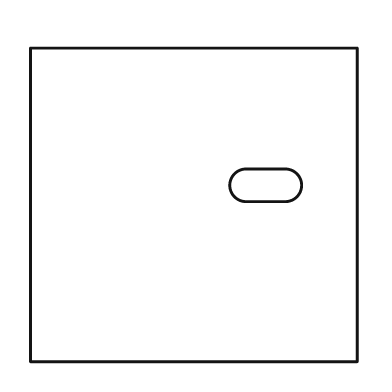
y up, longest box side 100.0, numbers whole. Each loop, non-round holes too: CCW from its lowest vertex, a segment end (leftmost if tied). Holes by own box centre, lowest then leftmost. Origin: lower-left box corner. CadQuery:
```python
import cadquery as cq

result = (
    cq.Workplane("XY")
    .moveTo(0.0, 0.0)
    .lineTo(100.0, 0.0)
    .lineTo(100.0, 96.0)
    .lineTo(0.0, 96.0)
    .close()
    .moveTo(66.0, 49.0)
    .lineTo(78.0, 49.0)
    .threePointArc((83.0, 54.0), (78.0, 59.0))
    .lineTo(66.0, 59.0)
    .threePointArc((61.0, 54.0), (66.0, 49.0))
    .close()
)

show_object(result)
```